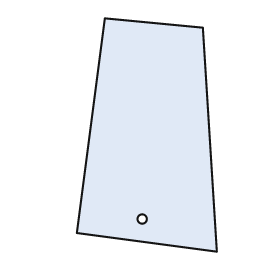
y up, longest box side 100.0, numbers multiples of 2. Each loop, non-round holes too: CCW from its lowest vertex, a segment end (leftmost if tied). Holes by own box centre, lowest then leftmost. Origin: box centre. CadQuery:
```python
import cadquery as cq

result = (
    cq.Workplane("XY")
    .moveTo(30.0, -50.0)
    .lineTo(24.0, 46.0)
    .lineTo(-18.0, 50.0)
    .lineTo(-30.0, -42.0)
    .close()
    .moveTo(-2.0, -36.0)
    .circle(2.0)
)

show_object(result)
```